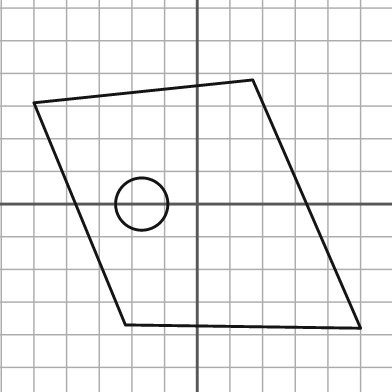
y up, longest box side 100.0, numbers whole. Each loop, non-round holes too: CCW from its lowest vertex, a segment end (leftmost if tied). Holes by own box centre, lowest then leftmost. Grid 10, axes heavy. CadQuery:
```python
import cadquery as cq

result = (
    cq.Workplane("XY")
    .moveTo(50.0, -38.0)
    .lineTo(17.0, 38.0)
    .lineTo(-50.0, 31.0)
    .lineTo(-22.0, -37.0)
    .close()
    .moveTo(-17.0, 0.0)
    .circle(8.0)
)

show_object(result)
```